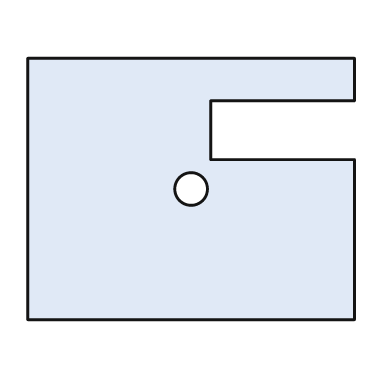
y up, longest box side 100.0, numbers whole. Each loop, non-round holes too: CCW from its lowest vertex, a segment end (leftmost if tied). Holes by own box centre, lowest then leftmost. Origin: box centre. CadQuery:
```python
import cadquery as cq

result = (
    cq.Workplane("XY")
    .moveTo(-50.0, -40.0)
    .lineTo(50.0, -40.0)
    .lineTo(50.0, 9.0)
    .lineTo(6.0, 9.0)
    .lineTo(6.0, 27.0)
    .lineTo(50.0, 27.0)
    .lineTo(50.0, 40.0)
    .lineTo(-50.0, 40.0)
    .close()
    .moveTo(0.0, 0.0)
    .circle(5.0)
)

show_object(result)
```